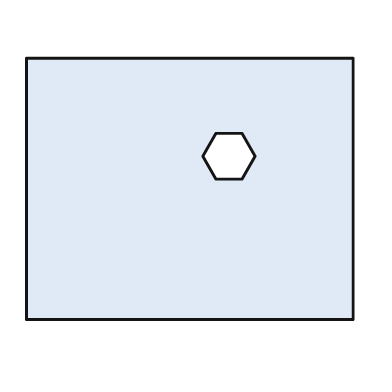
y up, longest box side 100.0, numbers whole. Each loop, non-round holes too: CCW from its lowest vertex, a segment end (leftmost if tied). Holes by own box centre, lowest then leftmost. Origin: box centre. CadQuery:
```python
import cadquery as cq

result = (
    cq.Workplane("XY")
    .moveTo(-50.0, -40.0)
    .lineTo(50.0, -40.0)
    .lineTo(50.0, 40.0)
    .lineTo(-50.0, 40.0)
    .close()
    .moveTo(8.0, 3.0)
    .lineTo(16.0, 3.0)
    .lineTo(20.0, 10.0)
    .lineTo(16.0, 17.0)
    .lineTo(8.0, 17.0)
    .lineTo(4.0, 10.0)
    .close()
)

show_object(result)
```